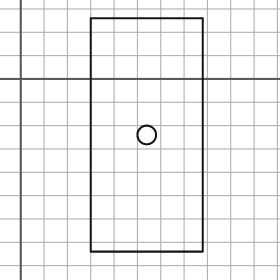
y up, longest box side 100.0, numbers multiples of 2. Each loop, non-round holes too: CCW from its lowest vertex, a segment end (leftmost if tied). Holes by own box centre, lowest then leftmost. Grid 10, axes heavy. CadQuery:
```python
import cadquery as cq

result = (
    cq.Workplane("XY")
    .moveTo(30.0, -74.0)
    .lineTo(78.0, -74.0)
    .lineTo(78.0, 26.0)
    .lineTo(30.0, 26.0)
    .close()
    .moveTo(54.0, -24.0)
    .circle(4.0)
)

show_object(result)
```